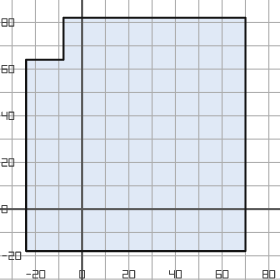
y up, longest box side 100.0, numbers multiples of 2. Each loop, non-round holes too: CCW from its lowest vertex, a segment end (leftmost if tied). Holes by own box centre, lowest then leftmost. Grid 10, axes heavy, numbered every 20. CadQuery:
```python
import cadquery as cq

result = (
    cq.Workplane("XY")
    .moveTo(-24.0, -18.0)
    .lineTo(70.0, -18.0)
    .lineTo(70.0, 82.0)
    .lineTo(-8.0, 82.0)
    .lineTo(-8.0, 64.0)
    .lineTo(-24.0, 64.0)
    .close()
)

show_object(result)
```